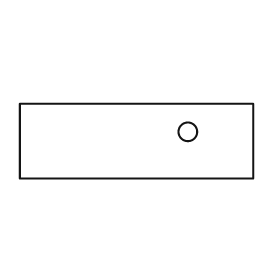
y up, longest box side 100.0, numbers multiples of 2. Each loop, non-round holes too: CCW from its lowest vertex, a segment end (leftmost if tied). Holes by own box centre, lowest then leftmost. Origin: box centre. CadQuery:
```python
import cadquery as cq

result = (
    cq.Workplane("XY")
    .moveTo(-50.0, -16.0)
    .lineTo(50.0, -16.0)
    .lineTo(50.0, 16.0)
    .lineTo(-50.0, 16.0)
    .close()
    .moveTo(22.0, 4.0)
    .circle(4.0)
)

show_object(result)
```